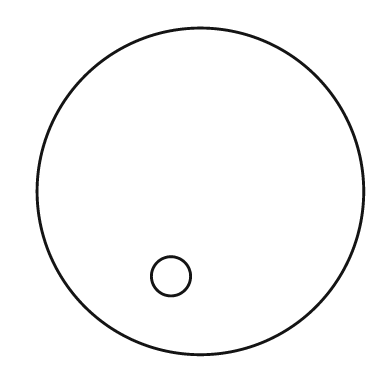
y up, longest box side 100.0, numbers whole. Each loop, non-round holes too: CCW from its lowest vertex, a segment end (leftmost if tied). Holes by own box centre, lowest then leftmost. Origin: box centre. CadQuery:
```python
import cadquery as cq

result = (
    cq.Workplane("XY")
    .moveTo(0.0, 0.0)
    .circle(50.0)
    .moveTo(-9.0, -26.0)
    .circle(6.0)
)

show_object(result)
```